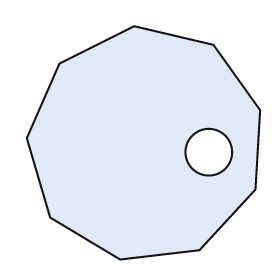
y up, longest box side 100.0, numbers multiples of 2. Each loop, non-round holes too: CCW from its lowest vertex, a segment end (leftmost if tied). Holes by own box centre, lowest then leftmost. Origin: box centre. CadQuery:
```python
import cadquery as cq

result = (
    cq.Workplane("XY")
    .moveTo(-10.0, -50.0)
    .lineTo(24.0, -46.0)
    .lineTo(48.0, -20.0)
    .lineTo(50.0, 14.0)
    .lineTo(30.0, 42.0)
    .lineTo(-4.0, 50.0)
    .lineTo(-36.0, 34.0)
    .lineTo(-50.0, 2.0)
    .lineTo(-40.0, -32.0)
    .close()
    .moveTo(28.0, -4.0)
    .circle(10.0)
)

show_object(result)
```